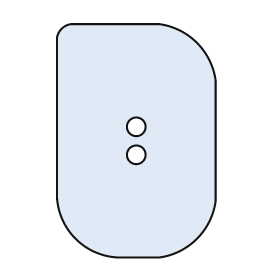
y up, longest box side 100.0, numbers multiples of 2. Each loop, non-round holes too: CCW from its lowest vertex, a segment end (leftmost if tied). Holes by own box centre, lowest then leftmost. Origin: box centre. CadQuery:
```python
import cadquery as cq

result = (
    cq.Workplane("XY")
    .moveTo(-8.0, -50.0)
    .lineTo(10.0, -50.0)
    .threePointArc((26.0, -42.0), (34.0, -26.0))
    .lineTo(34.0, 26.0)
    .threePointArc((26.0, 42.0), (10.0, 50.0))
    .lineTo(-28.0, 50.0)
    .threePointArc((-32.0, 48.0), (-34.0, 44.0))
    .lineTo(-34.0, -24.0)
    .threePointArc((-26.0, -42.0), (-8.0, -50.0))
    .close()
    .moveTo(0.0, -6.0)
    .circle(4.0)
    .moveTo(0.0, 6.0)
    .circle(4.0)
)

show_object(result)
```